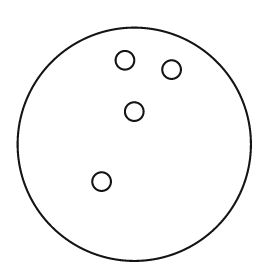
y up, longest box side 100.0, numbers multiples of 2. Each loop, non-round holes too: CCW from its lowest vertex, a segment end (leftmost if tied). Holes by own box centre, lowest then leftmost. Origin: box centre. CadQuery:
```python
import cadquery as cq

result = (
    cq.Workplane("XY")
    .moveTo(0.0, 0.0)
    .circle(50.0)
    .moveTo(-14.0, -16.0)
    .circle(4.0)
    .moveTo(0.0, 14.0)
    .circle(4.0)
    .moveTo(16.0, 32.0)
    .circle(4.0)
    .moveTo(-4.0, 36.0)
    .circle(4.0)
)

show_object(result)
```